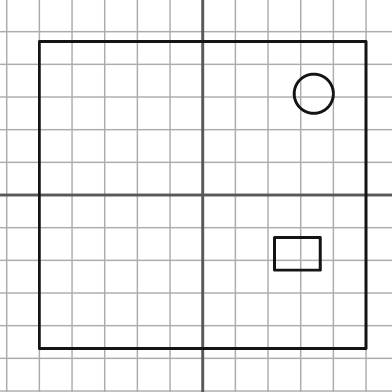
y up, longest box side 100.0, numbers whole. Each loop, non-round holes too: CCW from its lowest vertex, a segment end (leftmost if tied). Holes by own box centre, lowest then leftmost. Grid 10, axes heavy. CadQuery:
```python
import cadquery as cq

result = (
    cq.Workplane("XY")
    .moveTo(-50.0, -47.0)
    .lineTo(50.0, -47.0)
    .lineTo(50.0, 47.0)
    .lineTo(-50.0, 47.0)
    .close()
    .moveTo(22.0, -23.0)
    .lineTo(36.0, -23.0)
    .lineTo(36.0, -13.0)
    .lineTo(22.0, -13.0)
    .close()
    .moveTo(34.0, 31.0)
    .circle(6.0)
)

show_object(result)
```